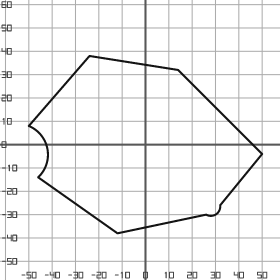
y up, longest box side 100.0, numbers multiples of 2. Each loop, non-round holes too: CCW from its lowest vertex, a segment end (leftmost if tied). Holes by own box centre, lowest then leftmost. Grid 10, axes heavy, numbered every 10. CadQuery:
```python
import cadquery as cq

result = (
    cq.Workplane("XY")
    .moveTo(-12.0, -38.0)
    .lineTo(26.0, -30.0)
    .threePointArc((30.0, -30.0), (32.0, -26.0))
    .lineTo(50.0, -4.0)
    .lineTo(14.0, 32.0)
    .lineTo(-24.0, 38.0)
    .lineTo(-50.0, 8.0)
    .threePointArc((-42.0, -2.0), (-46.0, -14.0))
    .close()
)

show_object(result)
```